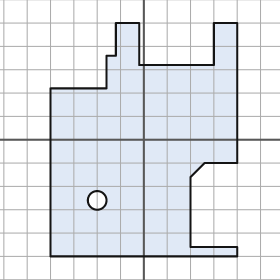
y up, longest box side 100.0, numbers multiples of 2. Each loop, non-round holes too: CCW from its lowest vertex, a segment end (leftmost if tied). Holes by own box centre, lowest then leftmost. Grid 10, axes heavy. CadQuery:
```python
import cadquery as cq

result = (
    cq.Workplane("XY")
    .moveTo(-40.0, -50.0)
    .lineTo(40.0, -50.0)
    .lineTo(40.0, -46.0)
    .lineTo(20.0, -46.0)
    .lineTo(20.0, -16.0)
    .lineTo(26.0, -10.0)
    .lineTo(40.0, -10.0)
    .lineTo(40.0, 50.0)
    .lineTo(30.0, 50.0)
    .lineTo(30.0, 32.0)
    .lineTo(-2.0, 32.0)
    .lineTo(-2.0, 50.0)
    .lineTo(-12.0, 50.0)
    .lineTo(-12.0, 36.0)
    .lineTo(-16.0, 36.0)
    .lineTo(-16.0, 22.0)
    .lineTo(-40.0, 22.0)
    .close()
    .moveTo(-20.0, -26.0)
    .circle(4.0)
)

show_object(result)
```